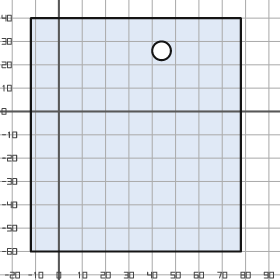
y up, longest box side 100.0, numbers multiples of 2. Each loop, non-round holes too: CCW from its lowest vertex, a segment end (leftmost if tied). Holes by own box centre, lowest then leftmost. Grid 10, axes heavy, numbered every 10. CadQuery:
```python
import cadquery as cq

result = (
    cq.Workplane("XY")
    .moveTo(-12.0, -60.0)
    .lineTo(78.0, -60.0)
    .lineTo(78.0, 40.0)
    .lineTo(-12.0, 40.0)
    .close()
    .moveTo(44.0, 26.0)
    .circle(4.0)
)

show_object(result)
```